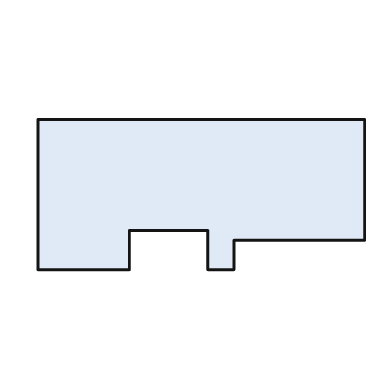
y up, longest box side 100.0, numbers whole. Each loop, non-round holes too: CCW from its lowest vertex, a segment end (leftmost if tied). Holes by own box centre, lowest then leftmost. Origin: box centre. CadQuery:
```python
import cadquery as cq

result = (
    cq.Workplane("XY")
    .moveTo(-50.0, -23.0)
    .lineTo(-22.0, -23.0)
    .lineTo(-22.0, -11.0)
    .lineTo(2.0, -11.0)
    .lineTo(2.0, -23.0)
    .lineTo(10.0, -23.0)
    .lineTo(10.0, -14.0)
    .lineTo(50.0, -14.0)
    .lineTo(50.0, 23.0)
    .lineTo(-50.0, 23.0)
    .close()
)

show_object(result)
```